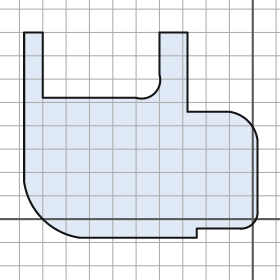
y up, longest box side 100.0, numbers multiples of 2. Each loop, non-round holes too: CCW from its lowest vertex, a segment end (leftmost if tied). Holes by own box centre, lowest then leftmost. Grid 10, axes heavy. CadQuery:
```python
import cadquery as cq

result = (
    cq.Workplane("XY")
    .moveTo(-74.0, -8.0)
    .lineTo(-24.0, -8.0)
    .lineTo(-24.0, -4.0)
    .lineTo(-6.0, -4.0)
    .threePointArc((0.0, -2.0), (2.0, 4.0))
    .lineTo(2.0, 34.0)
    .threePointArc((-2.0, 42.0), (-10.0, 46.0))
    .lineTo(-28.0, 46.0)
    .lineTo(-28.0, 80.0)
    .lineTo(-40.0, 80.0)
    .lineTo(-40.0, 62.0)
    .threePointArc((-42.0, 54.0), (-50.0, 52.0))
    .lineTo(-90.0, 52.0)
    .lineTo(-90.0, 80.0)
    .lineTo(-98.0, 80.0)
    .lineTo(-98.0, 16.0)
    .threePointArc((-90.0, 0.0), (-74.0, -8.0))
    .close()
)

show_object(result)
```